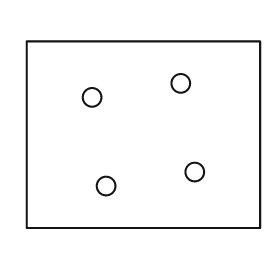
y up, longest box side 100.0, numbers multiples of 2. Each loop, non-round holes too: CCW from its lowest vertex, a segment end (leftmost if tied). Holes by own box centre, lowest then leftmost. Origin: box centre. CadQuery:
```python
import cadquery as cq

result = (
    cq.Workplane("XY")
    .moveTo(-50.0, -40.0)
    .lineTo(50.0, -40.0)
    .lineTo(50.0, 40.0)
    .lineTo(-50.0, 40.0)
    .close()
    .moveTo(-16.0, -22.0)
    .circle(4.0)
    .moveTo(22.0, -16.0)
    .circle(4.0)
    .moveTo(-22.0, 16.0)
    .circle(4.0)
    .moveTo(16.0, 22.0)
    .circle(4.0)
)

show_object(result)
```